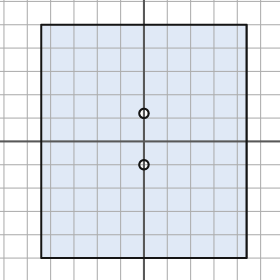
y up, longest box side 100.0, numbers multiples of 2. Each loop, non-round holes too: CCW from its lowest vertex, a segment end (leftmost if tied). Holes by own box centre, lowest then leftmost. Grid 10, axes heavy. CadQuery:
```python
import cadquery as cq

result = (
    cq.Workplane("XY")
    .moveTo(-44.0, -50.0)
    .lineTo(44.0, -50.0)
    .lineTo(44.0, 50.0)
    .lineTo(-44.0, 50.0)
    .close()
    .moveTo(0.0, -10.0)
    .circle(2.0)
    .moveTo(0.0, 12.0)
    .circle(2.0)
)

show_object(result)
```